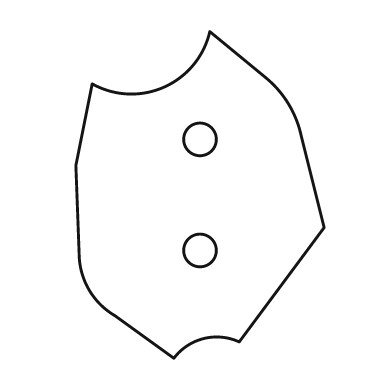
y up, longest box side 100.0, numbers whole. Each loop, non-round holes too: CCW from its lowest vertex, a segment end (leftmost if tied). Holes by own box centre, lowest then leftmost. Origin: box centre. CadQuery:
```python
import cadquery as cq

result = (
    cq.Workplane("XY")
    .moveTo(-8.0, -50.0)
    .threePointArc((1.0, -44.0), (12.0, -45.0))
    .lineTo(38.0, -10.0)
    .lineTo(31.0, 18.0)
    .threePointArc((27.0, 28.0), (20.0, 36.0))
    .lineTo(3.0, 50.0)
    .threePointArc((-11.0, 33.0), (-33.0, 34.0))
    .lineTo(-38.0, 9.0)
    .lineTo(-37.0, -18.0)
    .threePointArc((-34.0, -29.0), (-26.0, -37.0))
    .close()
    .moveTo(0.0, -17.0)
    .circle(5.0)
    .moveTo(0.0, 17.0)
    .circle(5.0)
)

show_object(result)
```